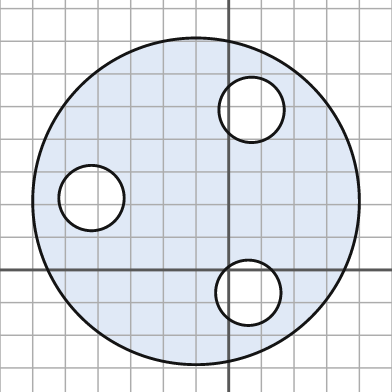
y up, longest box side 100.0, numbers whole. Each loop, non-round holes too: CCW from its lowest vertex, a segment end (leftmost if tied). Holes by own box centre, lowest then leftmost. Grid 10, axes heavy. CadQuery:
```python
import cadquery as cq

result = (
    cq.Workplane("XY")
    .moveTo(-10.0, 21.0)
    .circle(50.0)
    .moveTo(6.0, -7.0)
    .circle(10.0)
    .moveTo(-42.0, 22.0)
    .circle(10.0)
    .moveTo(7.0, 49.0)
    .circle(10.0)
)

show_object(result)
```